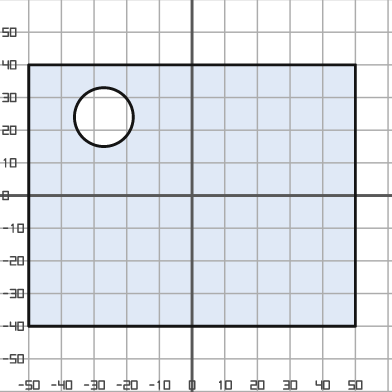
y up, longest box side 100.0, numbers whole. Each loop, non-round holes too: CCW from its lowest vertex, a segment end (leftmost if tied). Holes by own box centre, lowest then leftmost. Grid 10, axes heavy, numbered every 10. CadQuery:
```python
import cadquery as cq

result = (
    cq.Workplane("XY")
    .moveTo(-50.0, -40.0)
    .lineTo(50.0, -40.0)
    .lineTo(50.0, 40.0)
    .lineTo(-50.0, 40.0)
    .close()
    .moveTo(-27.0, 24.0)
    .circle(9.0)
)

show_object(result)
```